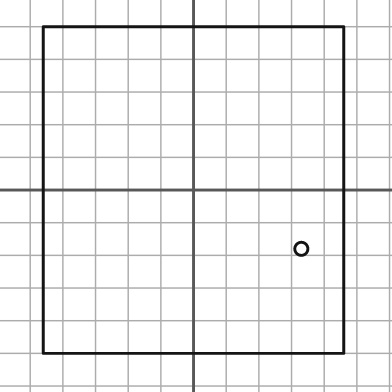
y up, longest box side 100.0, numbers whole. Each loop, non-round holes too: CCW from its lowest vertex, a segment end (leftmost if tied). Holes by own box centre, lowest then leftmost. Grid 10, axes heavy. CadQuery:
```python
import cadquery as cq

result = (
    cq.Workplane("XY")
    .moveTo(-46.0, -50.0)
    .lineTo(46.0, -50.0)
    .lineTo(46.0, 50.0)
    .lineTo(-46.0, 50.0)
    .close()
    .moveTo(33.0, -18.0)
    .circle(2.0)
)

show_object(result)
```